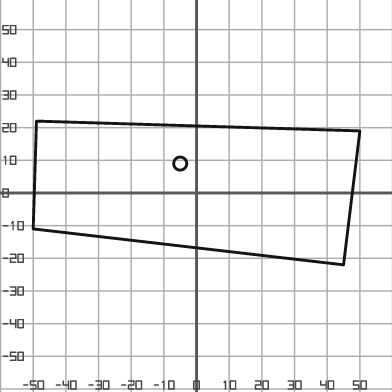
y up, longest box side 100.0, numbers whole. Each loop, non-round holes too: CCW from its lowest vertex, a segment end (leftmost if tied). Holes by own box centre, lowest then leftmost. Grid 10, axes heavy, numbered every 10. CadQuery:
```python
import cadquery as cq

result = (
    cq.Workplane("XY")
    .moveTo(45.0, -22.0)
    .lineTo(50.0, 19.0)
    .lineTo(-49.0, 22.0)
    .lineTo(-50.0, -11.0)
    .close()
    .moveTo(-5.0, 9.0)
    .circle(2.0)
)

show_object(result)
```